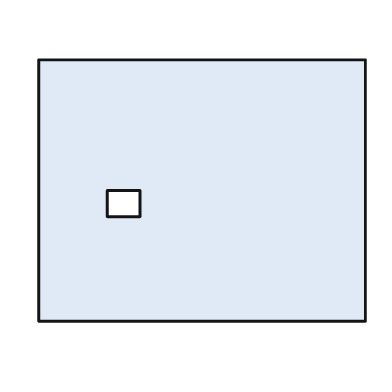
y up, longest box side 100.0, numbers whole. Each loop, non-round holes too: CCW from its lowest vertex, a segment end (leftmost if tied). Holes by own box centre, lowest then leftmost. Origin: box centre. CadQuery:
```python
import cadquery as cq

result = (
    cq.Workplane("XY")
    .moveTo(-50.0, -40.0)
    .lineTo(50.0, -40.0)
    .lineTo(50.0, 40.0)
    .lineTo(-50.0, 40.0)
    .close()
    .moveTo(-29.0, -8.0)
    .lineTo(-19.0, -8.0)
    .lineTo(-19.0, 0.0)
    .lineTo(-29.0, 0.0)
    .close()
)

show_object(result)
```